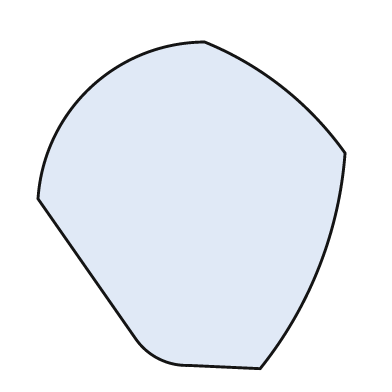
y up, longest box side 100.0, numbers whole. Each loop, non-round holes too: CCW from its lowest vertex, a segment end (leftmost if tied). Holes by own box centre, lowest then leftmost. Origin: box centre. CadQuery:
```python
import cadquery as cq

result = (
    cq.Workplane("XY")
    .moveTo(21.0, -50.0)
    .threePointArc((39.0, -19.0), (47.0, 16.0))
    .threePointArc((28.0, 36.0), (4.0, 50.0))
    .threePointArc((-31.0, 36.0), (-47.0, 2.0))
    .lineTo(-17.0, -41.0)
    .threePointArc((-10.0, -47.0), (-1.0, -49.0))
    .close()
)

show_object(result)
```